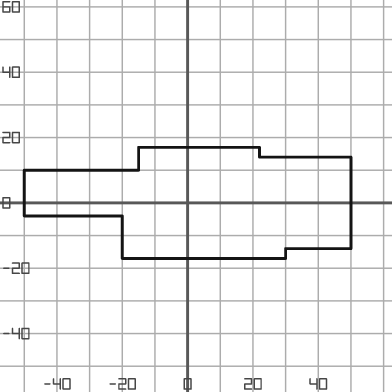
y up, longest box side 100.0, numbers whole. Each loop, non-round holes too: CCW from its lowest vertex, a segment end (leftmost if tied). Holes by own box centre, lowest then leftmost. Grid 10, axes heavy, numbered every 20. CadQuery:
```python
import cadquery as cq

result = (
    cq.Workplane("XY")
    .moveTo(-20.0, -17.0)
    .lineTo(30.0, -17.0)
    .lineTo(30.0, -14.0)
    .lineTo(50.0, -14.0)
    .lineTo(50.0, 14.0)
    .lineTo(22.0, 14.0)
    .lineTo(22.0, 17.0)
    .lineTo(-15.0, 17.0)
    .lineTo(-15.0, 10.0)
    .lineTo(-50.0, 10.0)
    .lineTo(-50.0, -4.0)
    .lineTo(-20.0, -4.0)
    .close()
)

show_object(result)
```